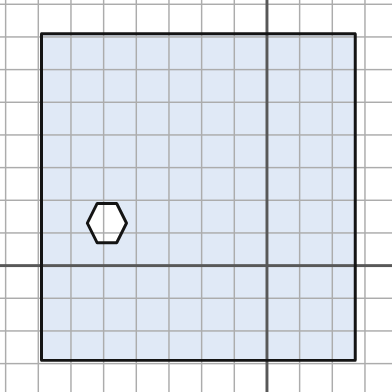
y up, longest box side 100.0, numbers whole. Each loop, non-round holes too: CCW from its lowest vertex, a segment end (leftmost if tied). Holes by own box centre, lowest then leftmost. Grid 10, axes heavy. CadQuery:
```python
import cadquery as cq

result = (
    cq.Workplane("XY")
    .moveTo(-69.0, -29.0)
    .lineTo(27.0, -29.0)
    .lineTo(27.0, 71.0)
    .lineTo(-69.0, 71.0)
    .close()
    .moveTo(-52.0, 7.0)
    .lineTo(-46.0, 7.0)
    .lineTo(-43.0, 13.0)
    .lineTo(-46.0, 19.0)
    .lineTo(-52.0, 19.0)
    .lineTo(-55.0, 13.0)
    .close()
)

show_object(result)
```